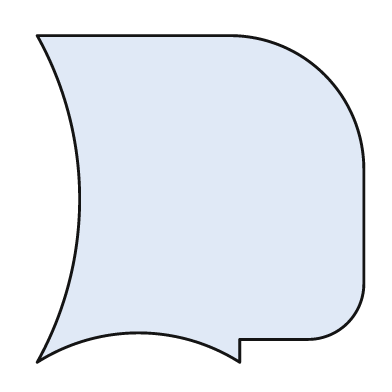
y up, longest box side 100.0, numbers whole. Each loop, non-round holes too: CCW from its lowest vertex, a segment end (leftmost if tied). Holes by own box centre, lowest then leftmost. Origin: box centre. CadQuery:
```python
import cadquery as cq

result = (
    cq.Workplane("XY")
    .moveTo(-50.0, -50.0)
    .threePointArc((-19.0, -41.0), (12.0, -50.0))
    .lineTo(12.0, -43.0)
    .lineTo(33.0, -43.0)
    .threePointArc((45.0, -38.0), (50.0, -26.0))
    .lineTo(50.0, 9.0)
    .threePointArc((38.0, 38.0), (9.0, 50.0))
    .lineTo(-50.0, 50.0)
    .threePointArc((-37.0, 0.0), (-50.0, -50.0))
    .close()
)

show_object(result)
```